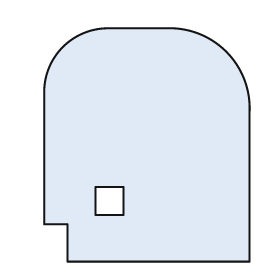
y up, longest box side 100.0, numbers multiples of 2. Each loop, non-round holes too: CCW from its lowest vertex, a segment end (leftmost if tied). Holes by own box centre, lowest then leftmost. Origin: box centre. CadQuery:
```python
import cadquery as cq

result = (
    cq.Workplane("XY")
    .moveTo(-34.0, -50.0)
    .lineTo(44.0, -50.0)
    .lineTo(44.0, 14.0)
    .threePointArc((34.0, 40.0), (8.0, 50.0))
    .lineTo(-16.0, 50.0)
    .threePointArc((-36.0, 42.0), (-44.0, 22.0))
    .lineTo(-44.0, -34.0)
    .lineTo(-34.0, -34.0)
    .close()
    .moveTo(-22.0, -30.0)
    .lineTo(-10.0, -30.0)
    .lineTo(-10.0, -18.0)
    .lineTo(-22.0, -18.0)
    .close()
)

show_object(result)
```